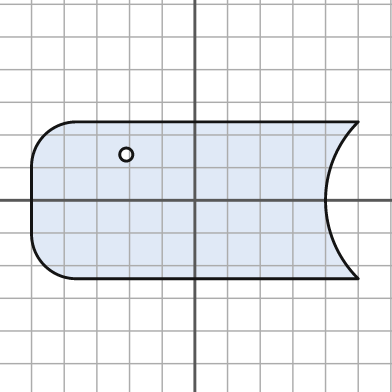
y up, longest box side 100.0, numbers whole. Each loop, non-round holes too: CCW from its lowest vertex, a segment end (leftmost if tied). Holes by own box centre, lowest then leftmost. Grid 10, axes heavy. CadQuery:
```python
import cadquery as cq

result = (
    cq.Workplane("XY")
    .moveTo(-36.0, -24.0)
    .lineTo(50.0, -24.0)
    .threePointArc((40.0, 0.0), (50.0, 24.0))
    .lineTo(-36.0, 24.0)
    .threePointArc((-46.0, 20.0), (-50.0, 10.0))
    .lineTo(-50.0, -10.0)
    .threePointArc((-46.0, -20.0), (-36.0, -24.0))
    .close()
    .moveTo(-21.0, 14.0)
    .circle(2.0)
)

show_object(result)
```